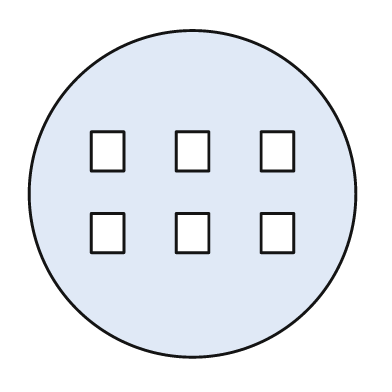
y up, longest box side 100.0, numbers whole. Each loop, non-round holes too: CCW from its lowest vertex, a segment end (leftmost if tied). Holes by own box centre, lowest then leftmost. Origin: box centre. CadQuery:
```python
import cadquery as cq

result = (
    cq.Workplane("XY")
    .moveTo(0.0, 0.0)
    .circle(50.0)
    .moveTo(-31.0, -18.0)
    .lineTo(-21.0, -18.0)
    .lineTo(-21.0, -6.0)
    .lineTo(-31.0, -6.0)
    .close()
    .moveTo(-5.0, -18.0)
    .lineTo(5.0, -18.0)
    .lineTo(5.0, -6.0)
    .lineTo(-5.0, -6.0)
    .close()
    .moveTo(21.0, -18.0)
    .lineTo(31.0, -18.0)
    .lineTo(31.0, -6.0)
    .lineTo(21.0, -6.0)
    .close()
    .moveTo(-31.0, 7.0)
    .lineTo(-21.0, 7.0)
    .lineTo(-21.0, 19.0)
    .lineTo(-31.0, 19.0)
    .close()
    .moveTo(-5.0, 7.0)
    .lineTo(5.0, 7.0)
    .lineTo(5.0, 19.0)
    .lineTo(-5.0, 19.0)
    .close()
    .moveTo(21.0, 7.0)
    .lineTo(31.0, 7.0)
    .lineTo(31.0, 19.0)
    .lineTo(21.0, 19.0)
    .close()
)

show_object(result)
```